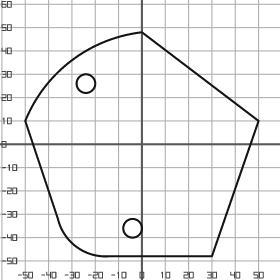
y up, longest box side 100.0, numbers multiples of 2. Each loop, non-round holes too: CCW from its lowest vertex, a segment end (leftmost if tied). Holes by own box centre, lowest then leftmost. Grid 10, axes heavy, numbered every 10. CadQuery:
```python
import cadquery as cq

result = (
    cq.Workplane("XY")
    .moveTo(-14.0, -48.0)
    .lineTo(30.0, -48.0)
    .lineTo(50.0, 10.0)
    .lineTo(0.0, 48.0)
    .threePointArc((-30.0, 36.0), (-50.0, 10.0))
    .lineTo(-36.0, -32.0)
    .threePointArc((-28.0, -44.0), (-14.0, -48.0))
    .close()
    .moveTo(-4.0, -36.0)
    .circle(4.0)
    .moveTo(-24.0, 26.0)
    .circle(4.0)
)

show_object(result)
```